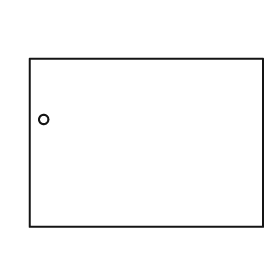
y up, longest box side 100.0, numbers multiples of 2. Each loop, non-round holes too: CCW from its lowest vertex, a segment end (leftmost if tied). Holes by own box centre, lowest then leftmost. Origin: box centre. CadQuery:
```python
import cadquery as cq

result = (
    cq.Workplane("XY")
    .moveTo(-50.0, -36.0)
    .lineTo(50.0, -36.0)
    .lineTo(50.0, 36.0)
    .lineTo(-50.0, 36.0)
    .close()
    .moveTo(-44.0, 10.0)
    .circle(2.0)
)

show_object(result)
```